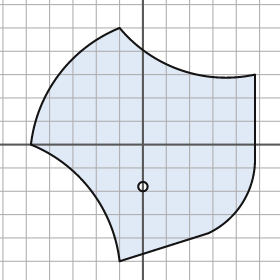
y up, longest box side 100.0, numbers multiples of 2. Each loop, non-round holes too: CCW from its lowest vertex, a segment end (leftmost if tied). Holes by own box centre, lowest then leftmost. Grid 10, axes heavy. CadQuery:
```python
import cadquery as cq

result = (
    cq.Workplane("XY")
    .moveTo(-10.0, -50.0)
    .lineTo(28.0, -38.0)
    .threePointArc((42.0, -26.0), (48.0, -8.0))
    .lineTo(48.0, 30.0)
    .threePointArc((16.0, 32.0), (-10.0, 50.0))
    .threePointArc((-36.0, 30.0), (-48.0, 0.0))
    .threePointArc((-22.0, -20.0), (-10.0, -50.0))
    .close()
    .moveTo(0.0, -18.0)
    .circle(2.0)
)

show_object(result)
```